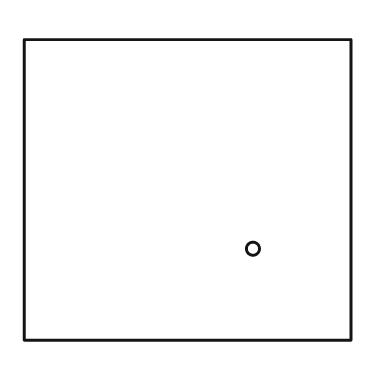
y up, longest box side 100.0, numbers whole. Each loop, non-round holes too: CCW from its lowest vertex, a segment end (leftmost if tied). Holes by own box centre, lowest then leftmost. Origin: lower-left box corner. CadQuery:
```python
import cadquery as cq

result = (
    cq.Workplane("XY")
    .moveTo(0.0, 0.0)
    .lineTo(100.0, 0.0)
    .lineTo(100.0, 92.0)
    .lineTo(0.0, 92.0)
    .close()
    .moveTo(70.0, 28.0)
    .circle(2.0)
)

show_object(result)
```